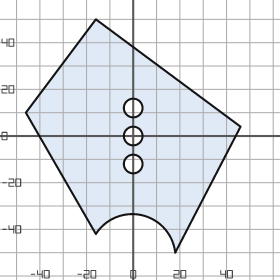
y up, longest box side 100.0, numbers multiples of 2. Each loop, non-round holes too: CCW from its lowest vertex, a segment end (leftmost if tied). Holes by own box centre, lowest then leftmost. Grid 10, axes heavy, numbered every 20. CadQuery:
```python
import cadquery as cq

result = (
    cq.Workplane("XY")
    .moveTo(18.0, -50.0)
    .lineTo(46.0, 4.0)
    .lineTo(-16.0, 50.0)
    .lineTo(-46.0, 10.0)
    .lineTo(-16.0, -42.0)
    .threePointArc((4.0, -34.0), (18.0, -50.0))
    .close()
    .moveTo(0.0, -12.0)
    .circle(4.0)
    .moveTo(0.0, 0.0)
    .circle(4.0)
    .moveTo(0.0, 12.0)
    .circle(4.0)
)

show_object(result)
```